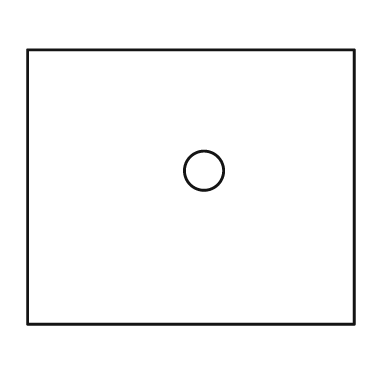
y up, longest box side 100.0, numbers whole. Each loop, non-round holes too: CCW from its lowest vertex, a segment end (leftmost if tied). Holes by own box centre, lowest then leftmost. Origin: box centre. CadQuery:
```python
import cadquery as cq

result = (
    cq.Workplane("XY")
    .moveTo(-50.0, -42.0)
    .lineTo(50.0, -42.0)
    .lineTo(50.0, 42.0)
    .lineTo(-50.0, 42.0)
    .close()
    .moveTo(4.0, 5.0)
    .circle(6.0)
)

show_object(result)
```